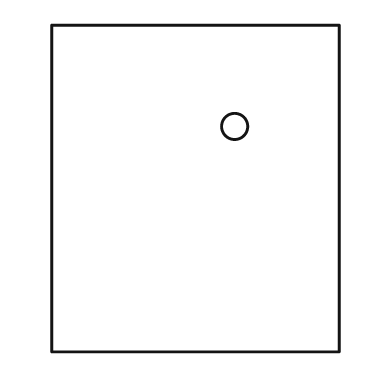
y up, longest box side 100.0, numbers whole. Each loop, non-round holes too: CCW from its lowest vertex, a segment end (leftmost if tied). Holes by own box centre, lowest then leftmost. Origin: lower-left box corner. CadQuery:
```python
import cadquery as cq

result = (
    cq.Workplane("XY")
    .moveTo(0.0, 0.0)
    .lineTo(88.0, 0.0)
    .lineTo(88.0, 100.0)
    .lineTo(0.0, 100.0)
    .close()
    .moveTo(56.0, 69.0)
    .circle(4.0)
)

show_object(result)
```